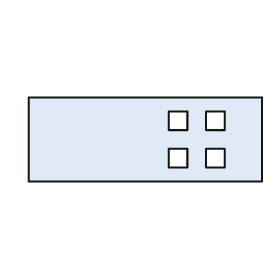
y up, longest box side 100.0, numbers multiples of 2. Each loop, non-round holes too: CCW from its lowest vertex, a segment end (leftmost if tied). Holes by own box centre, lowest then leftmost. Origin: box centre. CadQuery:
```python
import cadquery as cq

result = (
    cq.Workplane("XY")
    .moveTo(-50.0, -18.0)
    .lineTo(50.0, -18.0)
    .lineTo(50.0, 18.0)
    .lineTo(-50.0, 18.0)
    .close()
    .moveTo(10.0, -12.0)
    .lineTo(18.0, -12.0)
    .lineTo(18.0, -4.0)
    .lineTo(10.0, -4.0)
    .close()
    .moveTo(26.0, -12.0)
    .lineTo(34.0, -12.0)
    .lineTo(34.0, -4.0)
    .lineTo(26.0, -4.0)
    .close()
    .moveTo(10.0, 4.0)
    .lineTo(18.0, 4.0)
    .lineTo(18.0, 12.0)
    .lineTo(10.0, 12.0)
    .close()
    .moveTo(26.0, 4.0)
    .lineTo(34.0, 4.0)
    .lineTo(34.0, 12.0)
    .lineTo(26.0, 12.0)
    .close()
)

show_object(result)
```